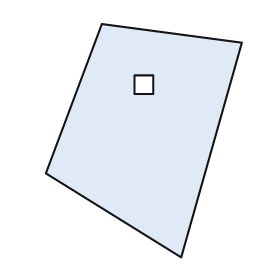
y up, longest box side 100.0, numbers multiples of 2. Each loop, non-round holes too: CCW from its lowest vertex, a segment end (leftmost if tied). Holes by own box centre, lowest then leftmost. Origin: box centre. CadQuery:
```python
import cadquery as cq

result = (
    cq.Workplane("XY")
    .moveTo(16.0, -50.0)
    .lineTo(42.0, 42.0)
    .lineTo(-18.0, 50.0)
    .lineTo(-42.0, -14.0)
    .close()
    .moveTo(-4.0, 20.0)
    .lineTo(4.0, 20.0)
    .lineTo(4.0, 28.0)
    .lineTo(-4.0, 28.0)
    .close()
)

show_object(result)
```